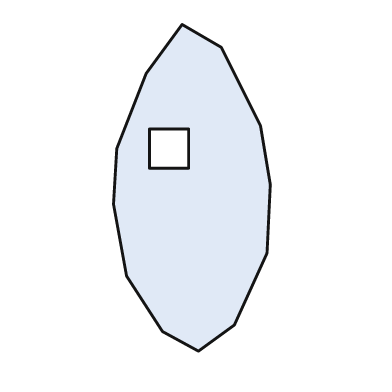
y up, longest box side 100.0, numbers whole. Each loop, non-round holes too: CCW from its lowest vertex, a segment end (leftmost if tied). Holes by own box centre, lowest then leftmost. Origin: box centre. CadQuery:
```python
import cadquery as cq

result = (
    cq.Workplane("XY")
    .moveTo(2.0, -50.0)
    .lineTo(13.0, -42.0)
    .lineTo(23.0, -20.0)
    .lineTo(24.0, 1.0)
    .lineTo(21.0, 19.0)
    .lineTo(9.0, 43.0)
    .lineTo(-3.0, 50.0)
    .lineTo(-14.0, 35.0)
    .lineTo(-23.0, 12.0)
    .lineTo(-24.0, -5.0)
    .lineTo(-20.0, -27.0)
    .lineTo(-9.0, -44.0)
    .close()
    .moveTo(-13.0, 6.0)
    .lineTo(-1.0, 6.0)
    .lineTo(-1.0, 18.0)
    .lineTo(-13.0, 18.0)
    .close()
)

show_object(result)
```